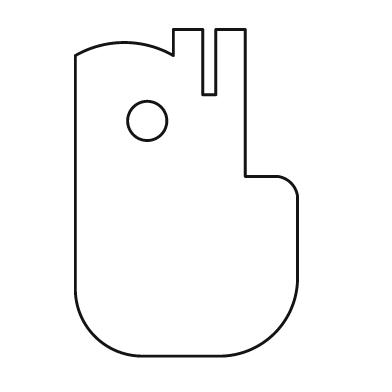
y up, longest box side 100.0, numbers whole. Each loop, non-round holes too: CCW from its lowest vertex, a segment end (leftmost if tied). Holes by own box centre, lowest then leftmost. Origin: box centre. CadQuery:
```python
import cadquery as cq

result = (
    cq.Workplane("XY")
    .moveTo(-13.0, -50.0)
    .lineTo(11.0, -50.0)
    .threePointArc((27.0, -43.0), (34.0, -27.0))
    .lineTo(34.0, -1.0)
    .threePointArc((32.0, 3.0), (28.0, 5.0))
    .lineTo(18.0, 5.0)
    .lineTo(18.0, 50.0)
    .lineTo(9.0, 50.0)
    .lineTo(9.0, 30.0)
    .lineTo(5.0, 30.0)
    .lineTo(5.0, 50.0)
    .lineTo(-4.0, 50.0)
    .lineTo(-4.0, 42.0)
    .threePointArc((-19.0, 46.0), (-34.0, 42.0))
    .lineTo(-34.0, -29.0)
    .threePointArc((-28.0, -44.0), (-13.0, -50.0))
    .close()
    .moveTo(-12.0, 22.0)
    .circle(6.0)
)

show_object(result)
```